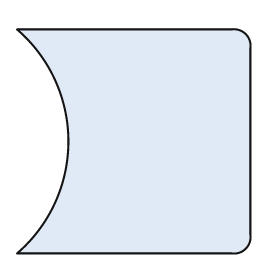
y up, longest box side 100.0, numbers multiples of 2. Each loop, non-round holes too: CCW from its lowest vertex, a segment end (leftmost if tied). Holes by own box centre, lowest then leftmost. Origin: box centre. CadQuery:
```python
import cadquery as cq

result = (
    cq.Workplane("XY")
    .moveTo(-50.0, -48.0)
    .lineTo(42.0, -48.0)
    .threePointArc((48.0, -46.0), (50.0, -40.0))
    .lineTo(50.0, 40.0)
    .threePointArc((48.0, 46.0), (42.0, 48.0))
    .lineTo(-50.0, 48.0)
    .threePointArc((-28.0, 0.0), (-50.0, -48.0))
    .close()
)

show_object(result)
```